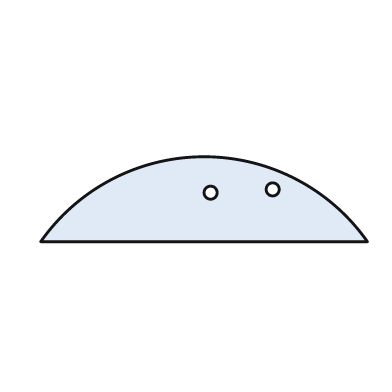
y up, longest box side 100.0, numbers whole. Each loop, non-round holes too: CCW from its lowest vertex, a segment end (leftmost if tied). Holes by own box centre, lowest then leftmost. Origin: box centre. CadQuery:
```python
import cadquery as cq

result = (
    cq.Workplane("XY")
    .moveTo(-50.0, -13.0)
    .lineTo(50.0, -13.0)
    .threePointArc((0.0, 13.0), (-50.0, -13.0))
    .close()
    .moveTo(2.0, 2.0)
    .circle(2.0)
    .moveTo(21.0, 3.0)
    .circle(2.0)
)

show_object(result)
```